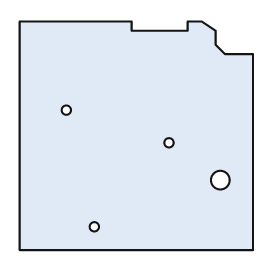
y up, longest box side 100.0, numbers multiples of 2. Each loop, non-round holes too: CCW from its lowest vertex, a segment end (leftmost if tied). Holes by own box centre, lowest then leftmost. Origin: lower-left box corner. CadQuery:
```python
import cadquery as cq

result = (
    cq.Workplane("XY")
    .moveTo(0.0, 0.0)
    .lineTo(100.0, 0.0)
    .lineTo(100.0, 84.0)
    .lineTo(88.0, 84.0)
    .lineTo(84.0, 88.0)
    .lineTo(84.0, 94.0)
    .lineTo(78.0, 98.0)
    .lineTo(72.0, 98.0)
    .lineTo(72.0, 94.0)
    .lineTo(48.0, 94.0)
    .lineTo(48.0, 98.0)
    .lineTo(0.0, 98.0)
    .close()
    .moveTo(32.0, 10.0)
    .circle(2.0)
    .moveTo(86.0, 30.0)
    .circle(4.0)
    .moveTo(64.0, 46.0)
    .circle(2.0)
    .moveTo(20.0, 60.0)
    .circle(2.0)
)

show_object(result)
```